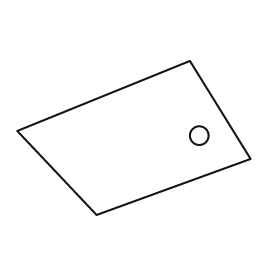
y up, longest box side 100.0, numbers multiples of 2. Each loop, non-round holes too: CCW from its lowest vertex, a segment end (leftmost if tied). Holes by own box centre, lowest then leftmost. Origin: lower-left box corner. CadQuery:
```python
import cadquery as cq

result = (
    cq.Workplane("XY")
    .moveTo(34.0, 0.0)
    .lineTo(100.0, 24.0)
    .lineTo(74.0, 66.0)
    .lineTo(0.0, 36.0)
    .close()
    .moveTo(78.0, 34.0)
    .circle(4.0)
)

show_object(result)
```